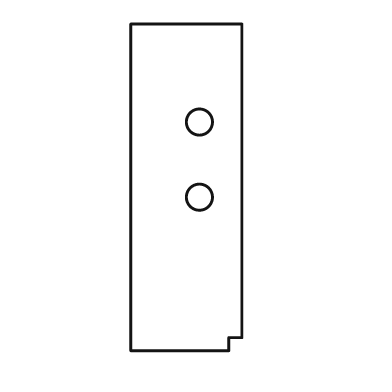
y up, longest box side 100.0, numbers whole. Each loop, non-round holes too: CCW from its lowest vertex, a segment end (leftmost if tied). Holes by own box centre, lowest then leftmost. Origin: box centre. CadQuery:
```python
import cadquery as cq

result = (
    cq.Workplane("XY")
    .moveTo(-17.0, -50.0)
    .lineTo(13.0, -50.0)
    .lineTo(13.0, -46.0)
    .lineTo(17.0, -46.0)
    .lineTo(17.0, 50.0)
    .lineTo(-17.0, 50.0)
    .close()
    .moveTo(4.0, -3.0)
    .circle(4.0)
    .moveTo(4.0, 20.0)
    .circle(4.0)
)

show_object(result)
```